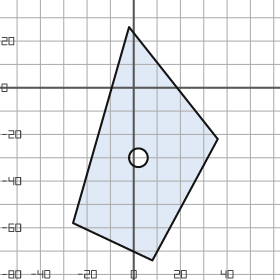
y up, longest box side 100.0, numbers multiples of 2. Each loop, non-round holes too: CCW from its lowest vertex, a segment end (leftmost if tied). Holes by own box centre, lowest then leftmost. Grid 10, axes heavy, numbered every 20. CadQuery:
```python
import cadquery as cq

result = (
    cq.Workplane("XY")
    .moveTo(8.0, -74.0)
    .lineTo(36.0, -22.0)
    .lineTo(-2.0, 26.0)
    .lineTo(-26.0, -58.0)
    .close()
    .moveTo(2.0, -30.0)
    .circle(4.0)
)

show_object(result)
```